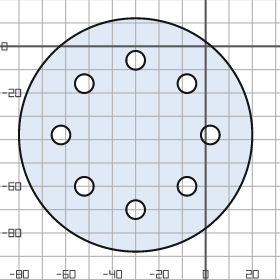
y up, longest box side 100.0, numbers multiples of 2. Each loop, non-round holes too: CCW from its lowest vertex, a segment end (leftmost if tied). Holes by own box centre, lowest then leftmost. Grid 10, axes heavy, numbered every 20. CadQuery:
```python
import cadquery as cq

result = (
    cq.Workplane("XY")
    .moveTo(-30.0, -38.0)
    .circle(50.0)
    .moveTo(-30.0, -70.0)
    .circle(4.0)
    .moveTo(-52.0, -60.0)
    .circle(4.0)
    .moveTo(-8.0, -60.0)
    .circle(4.0)
    .moveTo(-62.0, -38.0)
    .circle(4.0)
    .moveTo(2.0, -38.0)
    .circle(4.0)
    .moveTo(-52.0, -16.0)
    .circle(4.0)
    .moveTo(-8.0, -16.0)
    .circle(4.0)
    .moveTo(-30.0, -6.0)
    .circle(4.0)
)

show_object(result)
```